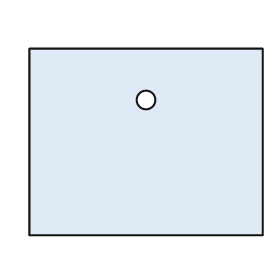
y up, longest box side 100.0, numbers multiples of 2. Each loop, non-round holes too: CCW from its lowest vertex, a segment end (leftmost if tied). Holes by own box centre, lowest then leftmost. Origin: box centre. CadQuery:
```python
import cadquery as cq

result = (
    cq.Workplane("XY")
    .moveTo(-50.0, -40.0)
    .lineTo(50.0, -40.0)
    .lineTo(50.0, 40.0)
    .lineTo(-50.0, 40.0)
    .close()
    .moveTo(0.0, 18.0)
    .circle(4.0)
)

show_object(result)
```